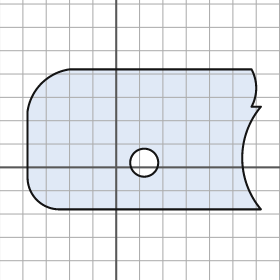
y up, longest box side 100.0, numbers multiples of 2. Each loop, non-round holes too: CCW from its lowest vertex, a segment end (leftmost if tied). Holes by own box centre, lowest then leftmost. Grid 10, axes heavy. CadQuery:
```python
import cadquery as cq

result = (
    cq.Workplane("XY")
    .moveTo(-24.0, -18.0)
    .lineTo(62.0, -18.0)
    .threePointArc((54.0, 4.0), (62.0, 26.0))
    .lineTo(58.0, 26.0)
    .threePointArc((60.0, 34.0), (58.0, 42.0))
    .lineTo(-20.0, 42.0)
    .threePointArc((-32.0, 36.0), (-38.0, 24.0))
    .lineTo(-38.0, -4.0)
    .threePointArc((-34.0, -14.0), (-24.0, -18.0))
    .close()
    .moveTo(12.0, 2.0)
    .circle(6.0)
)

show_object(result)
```